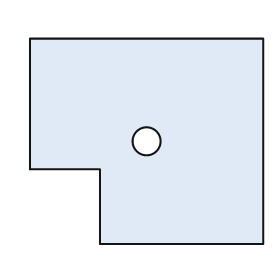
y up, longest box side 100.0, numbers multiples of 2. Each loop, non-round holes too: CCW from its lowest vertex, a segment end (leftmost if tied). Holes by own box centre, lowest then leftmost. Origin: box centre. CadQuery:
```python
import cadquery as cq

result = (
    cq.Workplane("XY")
    .moveTo(-20.0, -44.0)
    .lineTo(50.0, -44.0)
    .lineTo(50.0, 44.0)
    .lineTo(-50.0, 44.0)
    .lineTo(-50.0, -12.0)
    .lineTo(-20.0, -12.0)
    .close()
    .moveTo(0.0, 0.0)
    .circle(6.0)
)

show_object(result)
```